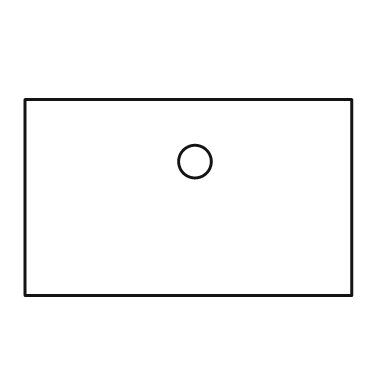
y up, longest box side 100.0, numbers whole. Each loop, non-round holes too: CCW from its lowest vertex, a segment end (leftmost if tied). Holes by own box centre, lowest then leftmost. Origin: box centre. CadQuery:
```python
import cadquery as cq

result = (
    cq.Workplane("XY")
    .moveTo(-50.0, -30.0)
    .lineTo(50.0, -30.0)
    .lineTo(50.0, 30.0)
    .lineTo(-50.0, 30.0)
    .close()
    .moveTo(2.0, 11.0)
    .circle(5.0)
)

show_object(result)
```